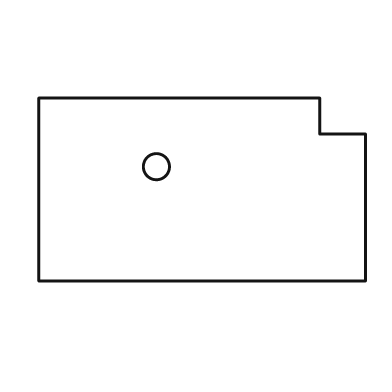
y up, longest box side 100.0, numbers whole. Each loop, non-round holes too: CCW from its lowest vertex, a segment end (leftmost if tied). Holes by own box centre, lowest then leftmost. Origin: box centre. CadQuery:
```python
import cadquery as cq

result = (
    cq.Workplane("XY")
    .moveTo(-50.0, -28.0)
    .lineTo(50.0, -28.0)
    .lineTo(50.0, 17.0)
    .lineTo(36.0, 17.0)
    .lineTo(36.0, 28.0)
    .lineTo(-50.0, 28.0)
    .close()
    .moveTo(-14.0, 7.0)
    .circle(4.0)
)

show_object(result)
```